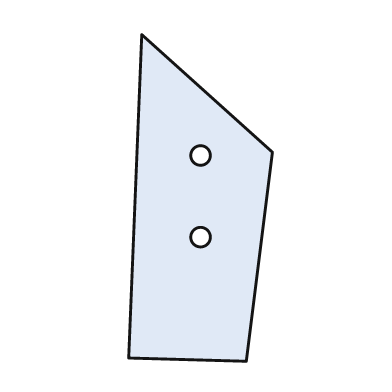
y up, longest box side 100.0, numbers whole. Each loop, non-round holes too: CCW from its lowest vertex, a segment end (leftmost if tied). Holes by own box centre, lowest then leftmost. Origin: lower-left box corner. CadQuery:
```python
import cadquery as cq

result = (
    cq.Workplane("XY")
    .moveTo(36.0, 0.0)
    .lineTo(44.0, 64.0)
    .lineTo(4.0, 100.0)
    .lineTo(0.0, 1.0)
    .close()
    .moveTo(22.0, 38.0)
    .circle(3.0)
    .moveTo(22.0, 63.0)
    .circle(3.0)
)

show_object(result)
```